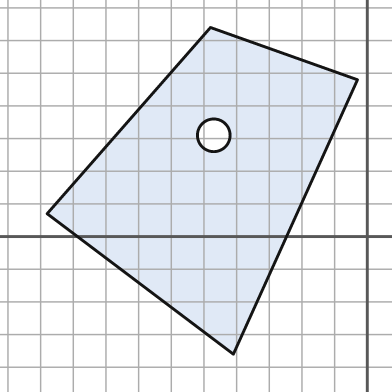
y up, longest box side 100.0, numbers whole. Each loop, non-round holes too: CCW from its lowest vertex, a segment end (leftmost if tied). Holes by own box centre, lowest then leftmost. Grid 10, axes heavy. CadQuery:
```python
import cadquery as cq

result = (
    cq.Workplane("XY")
    .moveTo(-41.0, -36.0)
    .lineTo(-3.0, 48.0)
    .lineTo(-48.0, 64.0)
    .lineTo(-98.0, 7.0)
    .close()
    .moveTo(-47.0, 31.0)
    .circle(5.0)
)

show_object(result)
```